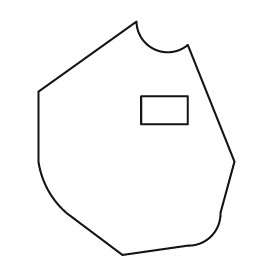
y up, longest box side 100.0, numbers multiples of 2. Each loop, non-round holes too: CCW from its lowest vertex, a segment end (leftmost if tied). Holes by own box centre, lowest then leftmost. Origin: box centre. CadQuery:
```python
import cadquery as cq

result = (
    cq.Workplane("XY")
    .moveTo(-6.0, -50.0)
    .lineTo(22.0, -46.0)
    .threePointArc((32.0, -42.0), (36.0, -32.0))
    .lineTo(42.0, -10.0)
    .lineTo(22.0, 40.0)
    .threePointArc((8.0, 38.0), (0.0, 50.0))
    .lineTo(-42.0, 20.0)
    .lineTo(-42.0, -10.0)
    .threePointArc((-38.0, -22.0), (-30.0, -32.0))
    .close()
    .moveTo(2.0, 6.0)
    .lineTo(22.0, 6.0)
    .lineTo(22.0, 18.0)
    .lineTo(2.0, 18.0)
    .close()
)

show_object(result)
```